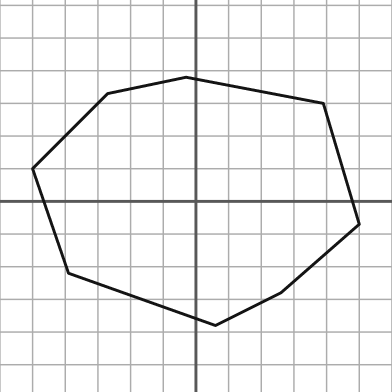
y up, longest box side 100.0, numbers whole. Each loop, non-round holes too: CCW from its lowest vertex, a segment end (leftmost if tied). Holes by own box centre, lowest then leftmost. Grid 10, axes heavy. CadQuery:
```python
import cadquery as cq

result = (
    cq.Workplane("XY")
    .moveTo(6.0, -38.0)
    .lineTo(26.0, -28.0)
    .lineTo(50.0, -7.0)
    .lineTo(39.0, 30.0)
    .lineTo(-3.0, 38.0)
    .lineTo(-27.0, 33.0)
    .lineTo(-50.0, 10.0)
    .lineTo(-39.0, -22.0)
    .close()
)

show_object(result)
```